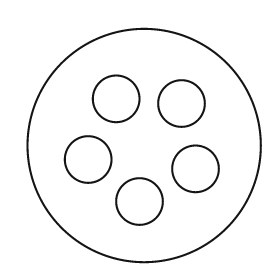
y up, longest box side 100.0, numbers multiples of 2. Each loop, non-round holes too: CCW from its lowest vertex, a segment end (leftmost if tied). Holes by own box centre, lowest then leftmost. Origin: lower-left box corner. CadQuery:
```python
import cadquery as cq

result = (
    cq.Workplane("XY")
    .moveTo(50.0, 50.0)
    .circle(50.0)
    .moveTo(48.0, 26.0)
    .circle(10.0)
    .moveTo(72.0, 40.0)
    .circle(10.0)
    .moveTo(26.0, 44.0)
    .circle(10.0)
    .moveTo(66.0, 68.0)
    .circle(10.0)
    .moveTo(38.0, 70.0)
    .circle(10.0)
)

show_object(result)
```